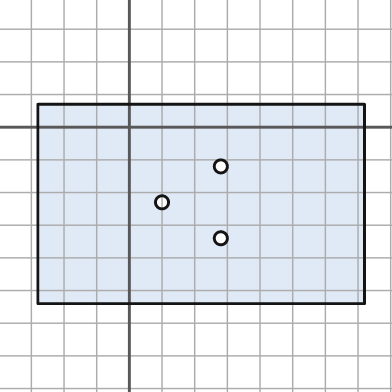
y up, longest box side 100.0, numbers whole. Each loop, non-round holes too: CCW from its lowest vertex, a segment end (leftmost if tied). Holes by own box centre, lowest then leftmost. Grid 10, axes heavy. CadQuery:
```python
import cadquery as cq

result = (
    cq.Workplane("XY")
    .moveTo(-28.0, -54.0)
    .lineTo(72.0, -54.0)
    .lineTo(72.0, 7.0)
    .lineTo(-28.0, 7.0)
    .close()
    .moveTo(28.0, -34.0)
    .circle(2.0)
    .moveTo(10.0, -23.0)
    .circle(2.0)
    .moveTo(28.0, -12.0)
    .circle(2.0)
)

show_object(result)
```